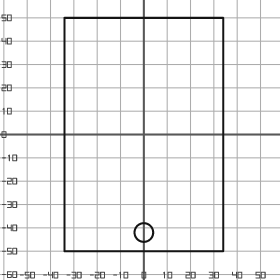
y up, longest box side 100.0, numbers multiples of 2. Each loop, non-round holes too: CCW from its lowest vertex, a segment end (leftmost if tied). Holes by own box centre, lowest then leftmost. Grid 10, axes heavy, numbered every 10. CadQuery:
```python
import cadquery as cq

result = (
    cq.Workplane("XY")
    .moveTo(-34.0, -50.0)
    .lineTo(34.0, -50.0)
    .lineTo(34.0, 50.0)
    .lineTo(-34.0, 50.0)
    .close()
    .moveTo(0.0, -42.0)
    .circle(4.0)
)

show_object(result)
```